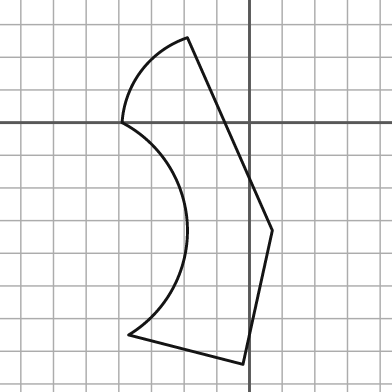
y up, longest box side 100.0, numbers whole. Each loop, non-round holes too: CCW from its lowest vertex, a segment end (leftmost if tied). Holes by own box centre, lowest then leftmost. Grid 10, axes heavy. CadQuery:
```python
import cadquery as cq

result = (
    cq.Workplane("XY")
    .moveTo(-2.0, -74.0)
    .lineTo(7.0, -33.0)
    .lineTo(-19.0, 26.0)
    .threePointArc((-33.0, 16.0), (-39.0, 0.0))
    .threePointArc((-19.0, -32.0), (-37.0, -65.0))
    .close()
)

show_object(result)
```